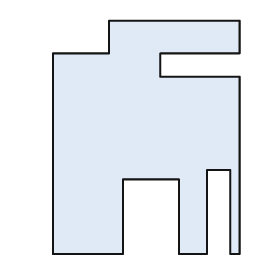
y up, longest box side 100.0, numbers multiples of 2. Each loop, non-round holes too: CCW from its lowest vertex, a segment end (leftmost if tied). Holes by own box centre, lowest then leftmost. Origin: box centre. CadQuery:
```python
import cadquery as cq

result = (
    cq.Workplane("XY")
    .moveTo(-40.0, -50.0)
    .lineTo(-10.0, -50.0)
    .lineTo(-10.0, -18.0)
    .lineTo(14.0, -18.0)
    .lineTo(14.0, -50.0)
    .lineTo(26.0, -50.0)
    .lineTo(26.0, -14.0)
    .lineTo(36.0, -14.0)
    .lineTo(36.0, -50.0)
    .lineTo(40.0, -50.0)
    .lineTo(40.0, 26.0)
    .lineTo(6.0, 26.0)
    .lineTo(6.0, 36.0)
    .lineTo(40.0, 36.0)
    .lineTo(40.0, 50.0)
    .lineTo(-16.0, 50.0)
    .lineTo(-16.0, 36.0)
    .lineTo(-40.0, 36.0)
    .close()
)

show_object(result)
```